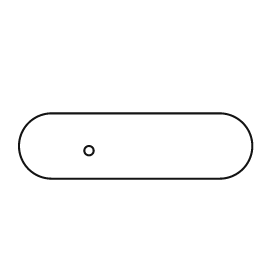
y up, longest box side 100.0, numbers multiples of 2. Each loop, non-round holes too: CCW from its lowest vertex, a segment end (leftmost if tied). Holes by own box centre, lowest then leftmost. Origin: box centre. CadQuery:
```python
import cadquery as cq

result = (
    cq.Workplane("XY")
    .moveTo(-36.0, -14.0)
    .lineTo(36.0, -14.0)
    .threePointArc((50.0, 0.0), (36.0, 14.0))
    .lineTo(-36.0, 14.0)
    .threePointArc((-50.0, 0.0), (-36.0, -14.0))
    .close()
    .moveTo(-20.0, -2.0)
    .circle(2.0)
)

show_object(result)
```